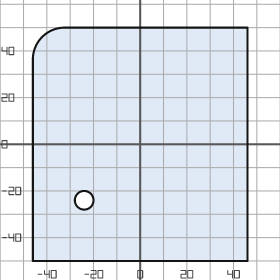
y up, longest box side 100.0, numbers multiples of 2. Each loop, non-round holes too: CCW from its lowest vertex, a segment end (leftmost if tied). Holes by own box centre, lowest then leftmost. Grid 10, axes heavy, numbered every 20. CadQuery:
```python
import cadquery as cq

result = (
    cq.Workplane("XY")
    .moveTo(-46.0, -50.0)
    .lineTo(46.0, -50.0)
    .lineTo(46.0, 50.0)
    .lineTo(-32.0, 50.0)
    .threePointArc((-42.0, 46.0), (-46.0, 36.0))
    .close()
    .moveTo(-24.0, -24.0)
    .circle(4.0)
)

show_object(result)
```